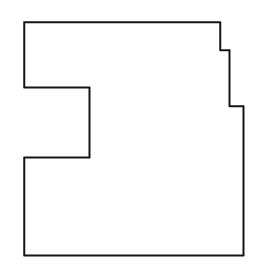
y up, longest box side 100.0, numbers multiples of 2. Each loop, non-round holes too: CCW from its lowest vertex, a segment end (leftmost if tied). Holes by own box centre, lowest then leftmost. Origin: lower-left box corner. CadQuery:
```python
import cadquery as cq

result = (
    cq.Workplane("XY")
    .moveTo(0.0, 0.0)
    .lineTo(94.0, 0.0)
    .lineTo(94.0, 64.0)
    .lineTo(88.0, 64.0)
    .lineTo(88.0, 88.0)
    .lineTo(84.0, 88.0)
    .lineTo(84.0, 100.0)
    .lineTo(0.0, 100.0)
    .lineTo(0.0, 72.0)
    .lineTo(28.0, 72.0)
    .lineTo(28.0, 42.0)
    .lineTo(0.0, 42.0)
    .close()
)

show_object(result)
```